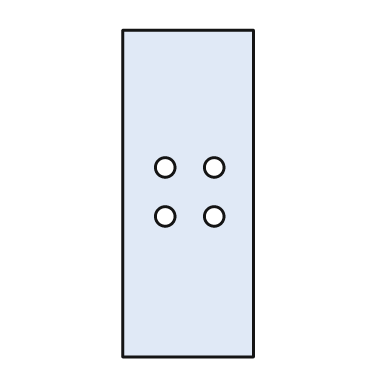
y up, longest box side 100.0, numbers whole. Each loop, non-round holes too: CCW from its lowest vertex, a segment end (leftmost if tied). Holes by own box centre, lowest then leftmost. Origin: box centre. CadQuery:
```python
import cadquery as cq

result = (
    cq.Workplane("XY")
    .moveTo(-20.0, -50.0)
    .lineTo(20.0, -50.0)
    .lineTo(20.0, 50.0)
    .lineTo(-20.0, 50.0)
    .close()
    .moveTo(-7.0, -7.0)
    .circle(3.0)
    .moveTo(8.0, -7.0)
    .circle(3.0)
    .moveTo(-7.0, 8.0)
    .circle(3.0)
    .moveTo(8.0, 8.0)
    .circle(3.0)
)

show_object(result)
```